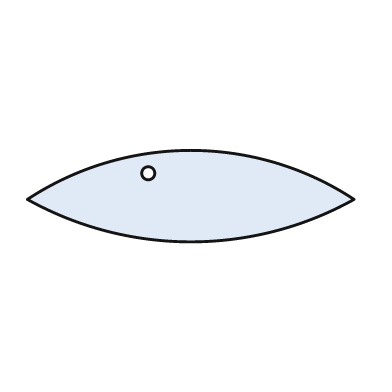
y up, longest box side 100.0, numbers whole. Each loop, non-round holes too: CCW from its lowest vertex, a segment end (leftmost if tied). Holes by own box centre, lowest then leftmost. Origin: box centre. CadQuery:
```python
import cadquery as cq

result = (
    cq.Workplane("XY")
    .moveTo(-50.0, -1.0)
    .threePointArc((0.0, -14.0), (50.0, -1.0))
    .threePointArc((0.0, 14.0), (-50.0, -1.0))
    .close()
    .moveTo(-13.0, 7.0)
    .circle(2.0)
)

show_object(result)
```